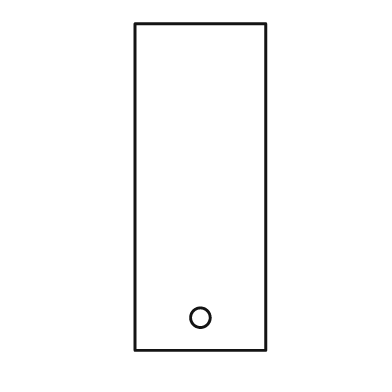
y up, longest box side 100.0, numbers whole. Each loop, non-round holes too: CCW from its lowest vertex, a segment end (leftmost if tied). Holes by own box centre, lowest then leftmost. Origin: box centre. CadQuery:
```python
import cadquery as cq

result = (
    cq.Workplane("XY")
    .moveTo(-20.0, -50.0)
    .lineTo(20.0, -50.0)
    .lineTo(20.0, 50.0)
    .lineTo(-20.0, 50.0)
    .close()
    .moveTo(0.0, -40.0)
    .circle(3.0)
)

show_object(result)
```